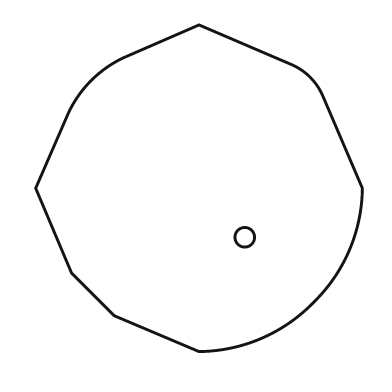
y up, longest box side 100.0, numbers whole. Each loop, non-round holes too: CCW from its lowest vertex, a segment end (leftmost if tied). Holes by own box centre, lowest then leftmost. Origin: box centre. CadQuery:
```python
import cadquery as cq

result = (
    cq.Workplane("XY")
    .moveTo(0.0, -50.0)
    .threePointArc((19.0, -46.0), (35.0, -35.0))
    .threePointArc((46.0, -19.0), (50.0, 0.0))
    .lineTo(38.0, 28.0)
    .threePointArc((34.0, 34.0), (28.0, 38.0))
    .lineTo(0.0, 50.0)
    .lineTo(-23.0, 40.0)
    .threePointArc((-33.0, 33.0), (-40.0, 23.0))
    .lineTo(-50.0, 0.0)
    .lineTo(-39.0, -26.0)
    .lineTo(-26.0, -39.0)
    .close()
    .moveTo(14.0, -15.0)
    .circle(3.0)
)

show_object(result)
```